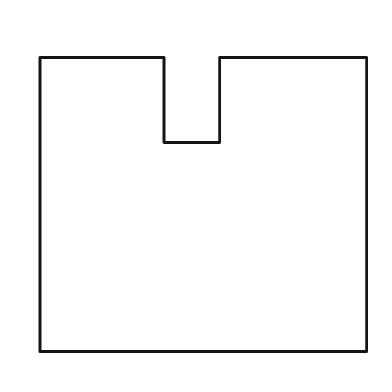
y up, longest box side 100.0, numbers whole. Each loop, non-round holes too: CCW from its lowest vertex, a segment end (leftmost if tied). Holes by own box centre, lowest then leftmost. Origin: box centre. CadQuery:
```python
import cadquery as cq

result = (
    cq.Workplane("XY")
    .moveTo(-50.0, -45.0)
    .lineTo(50.0, -45.0)
    .lineTo(50.0, 45.0)
    .lineTo(5.0, 45.0)
    .lineTo(5.0, 19.0)
    .lineTo(-12.0, 19.0)
    .lineTo(-12.0, 45.0)
    .lineTo(-50.0, 45.0)
    .close()
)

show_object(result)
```